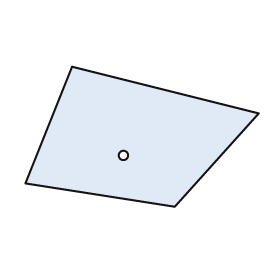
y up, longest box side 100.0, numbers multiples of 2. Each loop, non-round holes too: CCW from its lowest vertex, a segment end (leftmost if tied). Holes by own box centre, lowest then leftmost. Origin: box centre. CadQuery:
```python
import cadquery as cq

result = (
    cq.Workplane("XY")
    .moveTo(14.0, -30.0)
    .lineTo(50.0, 10.0)
    .lineTo(-30.0, 30.0)
    .lineTo(-50.0, -20.0)
    .close()
    .moveTo(-8.0, -8.0)
    .circle(2.0)
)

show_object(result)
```